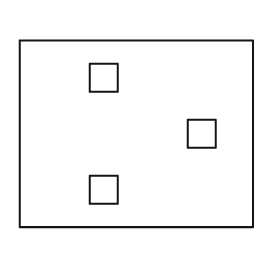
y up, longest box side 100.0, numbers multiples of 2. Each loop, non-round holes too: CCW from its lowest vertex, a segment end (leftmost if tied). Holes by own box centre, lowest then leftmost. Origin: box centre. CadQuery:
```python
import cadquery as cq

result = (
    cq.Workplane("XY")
    .moveTo(-50.0, -40.0)
    .lineTo(50.0, -40.0)
    .lineTo(50.0, 40.0)
    .lineTo(-50.0, 40.0)
    .close()
    .moveTo(-20.0, -30.0)
    .lineTo(-8.0, -30.0)
    .lineTo(-8.0, -18.0)
    .lineTo(-20.0, -18.0)
    .close()
    .moveTo(22.0, -6.0)
    .lineTo(34.0, -6.0)
    .lineTo(34.0, 6.0)
    .lineTo(22.0, 6.0)
    .close()
    .moveTo(-20.0, 18.0)
    .lineTo(-8.0, 18.0)
    .lineTo(-8.0, 30.0)
    .lineTo(-20.0, 30.0)
    .close()
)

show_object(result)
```